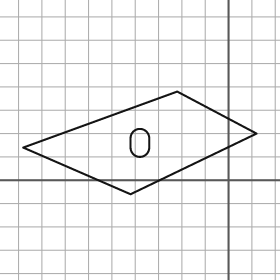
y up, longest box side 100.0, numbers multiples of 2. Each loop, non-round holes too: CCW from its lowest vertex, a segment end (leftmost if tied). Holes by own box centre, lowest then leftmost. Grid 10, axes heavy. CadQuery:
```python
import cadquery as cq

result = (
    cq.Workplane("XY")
    .moveTo(-42.0, -6.0)
    .lineTo(12.0, 20.0)
    .lineTo(-22.0, 38.0)
    .lineTo(-88.0, 14.0)
    .close()
    .moveTo(-42.0, 14.0)
    .threePointArc((-38.0, 10.0), (-34.0, 14.0))
    .lineTo(-34.0, 18.0)
    .threePointArc((-38.0, 22.0), (-42.0, 18.0))
    .close()
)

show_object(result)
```